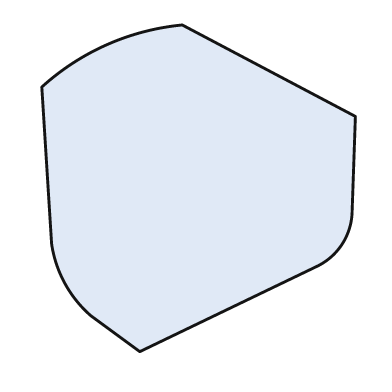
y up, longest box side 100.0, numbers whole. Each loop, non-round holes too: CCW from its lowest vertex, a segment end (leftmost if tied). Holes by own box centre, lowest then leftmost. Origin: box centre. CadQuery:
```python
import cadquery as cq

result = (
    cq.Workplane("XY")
    .moveTo(-18.0, -50.0)
    .lineTo(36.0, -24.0)
    .threePointArc((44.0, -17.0), (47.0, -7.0))
    .lineTo(48.0, 22.0)
    .lineTo(-5.0, 50.0)
    .threePointArc((-28.0, 44.0), (-48.0, 31.0))
    .lineTo(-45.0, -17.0)
    .threePointArc((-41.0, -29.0), (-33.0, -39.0))
    .close()
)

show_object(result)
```